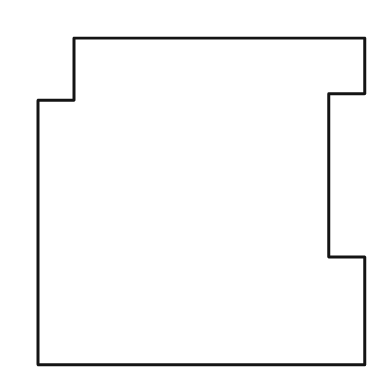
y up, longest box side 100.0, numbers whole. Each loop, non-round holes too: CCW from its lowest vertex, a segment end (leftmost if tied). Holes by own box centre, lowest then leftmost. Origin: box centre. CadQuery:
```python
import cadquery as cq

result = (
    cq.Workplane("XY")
    .moveTo(-50.0, -50.0)
    .lineTo(50.0, -50.0)
    .lineTo(50.0, -17.0)
    .lineTo(39.0, -17.0)
    .lineTo(39.0, 33.0)
    .lineTo(50.0, 33.0)
    .lineTo(50.0, 50.0)
    .lineTo(-39.0, 50.0)
    .lineTo(-39.0, 31.0)
    .lineTo(-50.0, 31.0)
    .close()
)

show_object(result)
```